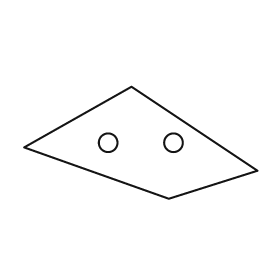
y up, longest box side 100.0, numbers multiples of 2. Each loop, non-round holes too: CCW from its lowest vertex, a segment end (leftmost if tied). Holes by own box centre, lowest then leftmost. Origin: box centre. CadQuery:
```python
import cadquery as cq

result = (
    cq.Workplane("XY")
    .moveTo(12.0, -24.0)
    .lineTo(50.0, -12.0)
    .lineTo(-4.0, 24.0)
    .lineTo(-50.0, -2.0)
    .close()
    .moveTo(-14.0, 0.0)
    .circle(4.0)
    .moveTo(14.0, 0.0)
    .circle(4.0)
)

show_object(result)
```